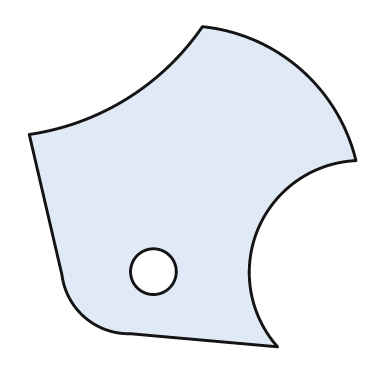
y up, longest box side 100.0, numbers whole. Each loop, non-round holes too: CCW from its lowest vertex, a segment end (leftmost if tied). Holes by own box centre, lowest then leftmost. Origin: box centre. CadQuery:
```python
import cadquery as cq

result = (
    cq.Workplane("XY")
    .moveTo(26.0, -49.0)
    .threePointArc((20.0, -13.0), (50.0, 8.0))
    .threePointArc((33.0, 36.0), (3.0, 49.0))
    .threePointArc((-20.0, 27.0), (-50.0, 16.0))
    .lineTo(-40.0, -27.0)
    .threePointArc((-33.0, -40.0), (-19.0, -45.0))
    .close()
    .moveTo(-12.0, -26.0)
    .circle(7.0)
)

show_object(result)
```